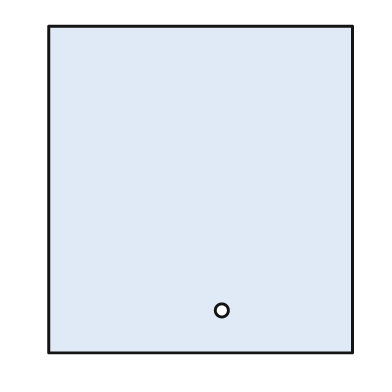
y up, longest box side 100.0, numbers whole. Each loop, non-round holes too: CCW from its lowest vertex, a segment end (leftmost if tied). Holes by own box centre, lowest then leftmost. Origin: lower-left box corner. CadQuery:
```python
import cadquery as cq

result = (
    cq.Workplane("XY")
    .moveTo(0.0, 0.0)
    .lineTo(93.0, 0.0)
    .lineTo(93.0, 100.0)
    .lineTo(0.0, 100.0)
    .close()
    .moveTo(53.0, 13.0)
    .circle(2.0)
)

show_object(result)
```